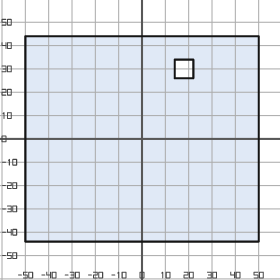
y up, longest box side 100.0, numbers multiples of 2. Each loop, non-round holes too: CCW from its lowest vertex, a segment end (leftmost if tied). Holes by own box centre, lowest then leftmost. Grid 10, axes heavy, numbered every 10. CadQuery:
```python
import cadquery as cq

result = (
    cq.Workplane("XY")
    .moveTo(-50.0, -44.0)
    .lineTo(50.0, -44.0)
    .lineTo(50.0, 44.0)
    .lineTo(-50.0, 44.0)
    .close()
    .moveTo(14.0, 26.0)
    .lineTo(22.0, 26.0)
    .lineTo(22.0, 34.0)
    .lineTo(14.0, 34.0)
    .close()
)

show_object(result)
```